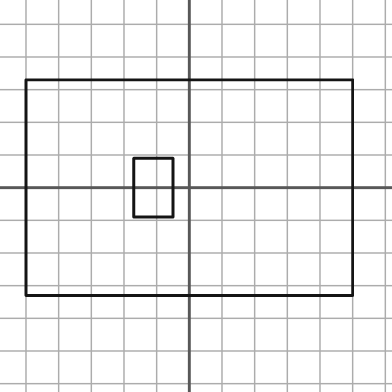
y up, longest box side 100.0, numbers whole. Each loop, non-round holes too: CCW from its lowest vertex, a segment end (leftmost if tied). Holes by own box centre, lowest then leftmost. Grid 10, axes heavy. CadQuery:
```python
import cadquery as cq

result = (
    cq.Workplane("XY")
    .moveTo(-50.0, -33.0)
    .lineTo(50.0, -33.0)
    .lineTo(50.0, 33.0)
    .lineTo(-50.0, 33.0)
    .close()
    .moveTo(-17.0, -9.0)
    .lineTo(-5.0, -9.0)
    .lineTo(-5.0, 9.0)
    .lineTo(-17.0, 9.0)
    .close()
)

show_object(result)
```